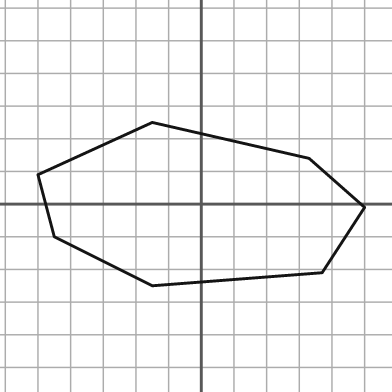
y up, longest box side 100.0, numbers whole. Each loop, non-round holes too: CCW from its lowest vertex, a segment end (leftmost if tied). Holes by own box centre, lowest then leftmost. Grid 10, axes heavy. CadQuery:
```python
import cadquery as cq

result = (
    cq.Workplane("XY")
    .moveTo(-15.0, -25.0)
    .lineTo(37.0, -21.0)
    .lineTo(50.0, -1.0)
    .lineTo(33.0, 14.0)
    .lineTo(-15.0, 25.0)
    .lineTo(-50.0, 9.0)
    .lineTo(-45.0, -10.0)
    .close()
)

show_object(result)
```